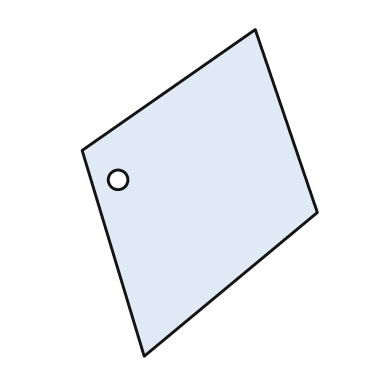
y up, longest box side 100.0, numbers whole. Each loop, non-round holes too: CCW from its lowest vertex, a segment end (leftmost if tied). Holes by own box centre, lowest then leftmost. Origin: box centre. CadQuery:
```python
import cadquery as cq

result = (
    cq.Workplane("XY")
    .moveTo(-17.0, -50.0)
    .lineTo(36.0, -6.0)
    .lineTo(17.0, 50.0)
    .lineTo(-36.0, 13.0)
    .close()
    .moveTo(-25.0, 4.0)
    .circle(3.0)
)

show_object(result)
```